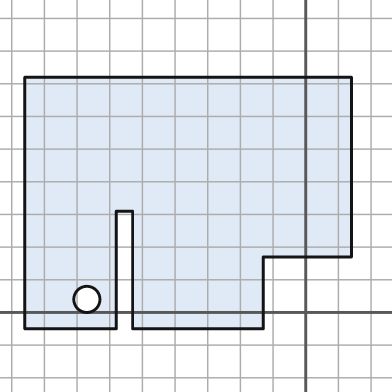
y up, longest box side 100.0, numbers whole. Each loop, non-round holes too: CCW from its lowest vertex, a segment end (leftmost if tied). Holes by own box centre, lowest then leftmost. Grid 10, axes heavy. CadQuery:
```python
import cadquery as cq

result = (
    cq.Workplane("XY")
    .moveTo(-86.0, -5.0)
    .lineTo(-58.0, -5.0)
    .lineTo(-58.0, 31.0)
    .lineTo(-53.0, 31.0)
    .lineTo(-53.0, -5.0)
    .lineTo(-13.0, -5.0)
    .lineTo(-13.0, 17.0)
    .lineTo(14.0, 17.0)
    .lineTo(14.0, 72.0)
    .lineTo(-86.0, 72.0)
    .close()
    .moveTo(-67.0, 4.0)
    .circle(4.0)
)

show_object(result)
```